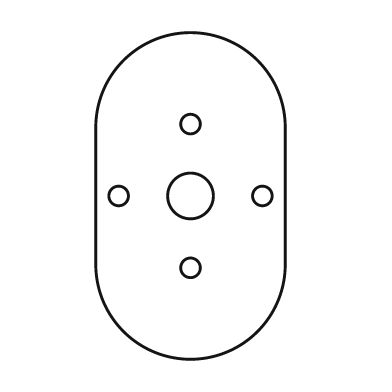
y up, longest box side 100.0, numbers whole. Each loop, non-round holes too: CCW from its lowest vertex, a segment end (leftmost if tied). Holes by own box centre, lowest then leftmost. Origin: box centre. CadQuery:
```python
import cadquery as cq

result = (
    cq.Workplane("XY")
    .moveTo(-29.0, -21.0)
    .threePointArc((0.0, -50.0), (29.0, -21.0))
    .lineTo(29.0, 21.0)
    .threePointArc((0.0, 50.0), (-29.0, 21.0))
    .close()
    .moveTo(0.0, -22.0)
    .circle(3.0)
    .moveTo(-22.0, 0.0)
    .circle(3.0)
    .moveTo(0.0, 0.0)
    .circle(7.0)
    .moveTo(22.0, 0.0)
    .circle(3.0)
    .moveTo(0.0, 22.0)
    .circle(3.0)
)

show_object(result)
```